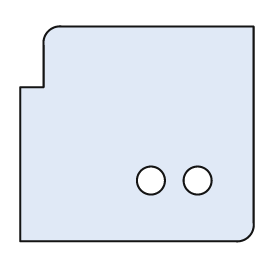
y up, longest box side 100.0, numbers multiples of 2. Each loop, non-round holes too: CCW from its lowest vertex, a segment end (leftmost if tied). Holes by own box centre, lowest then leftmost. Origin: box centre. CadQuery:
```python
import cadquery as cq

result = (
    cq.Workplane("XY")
    .moveTo(-50.0, -46.0)
    .lineTo(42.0, -46.0)
    .threePointArc((48.0, -44.0), (50.0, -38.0))
    .lineTo(50.0, 46.0)
    .lineTo(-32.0, 46.0)
    .threePointArc((-38.0, 44.0), (-40.0, 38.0))
    .lineTo(-40.0, 20.0)
    .lineTo(-50.0, 20.0)
    .close()
    .moveTo(6.0, -20.0)
    .circle(6.0)
    .moveTo(26.0, -20.0)
    .circle(6.0)
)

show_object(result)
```